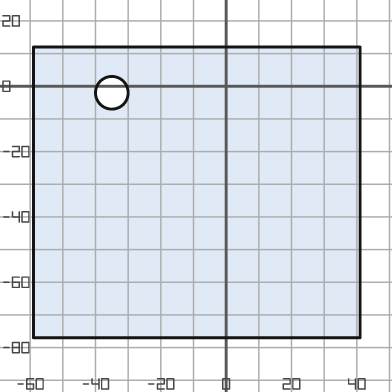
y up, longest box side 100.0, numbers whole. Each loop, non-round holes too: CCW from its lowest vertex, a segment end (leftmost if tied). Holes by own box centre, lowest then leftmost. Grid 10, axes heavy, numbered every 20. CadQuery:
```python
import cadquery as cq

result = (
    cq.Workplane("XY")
    .moveTo(-59.0, -77.0)
    .lineTo(41.0, -77.0)
    .lineTo(41.0, 12.0)
    .lineTo(-59.0, 12.0)
    .close()
    .moveTo(-35.0, -2.0)
    .circle(5.0)
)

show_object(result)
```